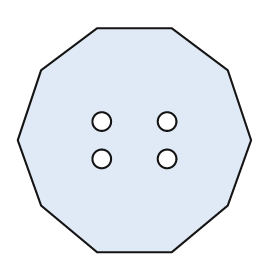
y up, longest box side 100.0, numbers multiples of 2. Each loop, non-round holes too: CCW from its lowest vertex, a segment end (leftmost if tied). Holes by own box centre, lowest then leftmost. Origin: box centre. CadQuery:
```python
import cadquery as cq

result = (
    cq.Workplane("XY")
    .moveTo(-16.0, -48.0)
    .lineTo(16.0, -48.0)
    .lineTo(40.0, -28.0)
    .lineTo(50.0, 0.0)
    .lineTo(40.0, 30.0)
    .lineTo(16.0, 48.0)
    .lineTo(-16.0, 48.0)
    .lineTo(-40.0, 30.0)
    .lineTo(-50.0, 0.0)
    .lineTo(-40.0, -28.0)
    .close()
    .moveTo(-14.0, -8.0)
    .circle(4.0)
    .moveTo(14.0, -8.0)
    .circle(4.0)
    .moveTo(-14.0, 8.0)
    .circle(4.0)
    .moveTo(14.0, 8.0)
    .circle(4.0)
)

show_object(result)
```